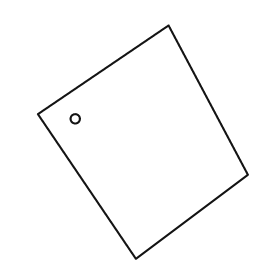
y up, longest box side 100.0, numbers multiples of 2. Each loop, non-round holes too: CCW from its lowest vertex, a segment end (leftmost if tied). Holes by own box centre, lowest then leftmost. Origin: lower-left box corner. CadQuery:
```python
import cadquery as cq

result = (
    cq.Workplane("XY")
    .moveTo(42.0, 0.0)
    .lineTo(90.0, 36.0)
    .lineTo(56.0, 100.0)
    .lineTo(0.0, 62.0)
    .close()
    .moveTo(16.0, 60.0)
    .circle(2.0)
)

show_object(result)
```